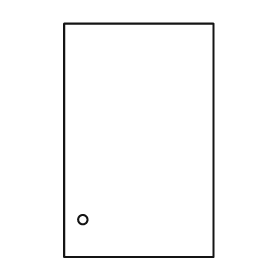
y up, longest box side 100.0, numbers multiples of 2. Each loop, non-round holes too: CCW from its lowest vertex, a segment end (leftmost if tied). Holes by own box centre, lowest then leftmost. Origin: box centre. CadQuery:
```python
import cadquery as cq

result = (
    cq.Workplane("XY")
    .moveTo(-32.0, -50.0)
    .lineTo(32.0, -50.0)
    .lineTo(32.0, 50.0)
    .lineTo(-32.0, 50.0)
    .close()
    .moveTo(-24.0, -34.0)
    .circle(2.0)
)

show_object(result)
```